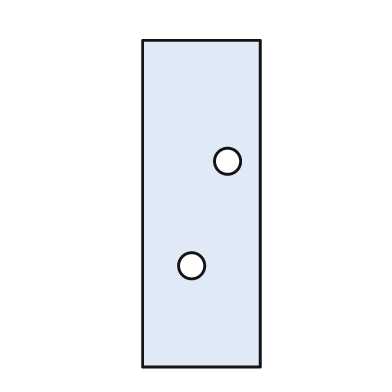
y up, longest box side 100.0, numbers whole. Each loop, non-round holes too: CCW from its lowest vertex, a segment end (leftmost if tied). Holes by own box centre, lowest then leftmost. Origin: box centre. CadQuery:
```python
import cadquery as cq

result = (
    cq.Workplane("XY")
    .moveTo(-18.0, -50.0)
    .lineTo(18.0, -50.0)
    .lineTo(18.0, 50.0)
    .lineTo(-18.0, 50.0)
    .close()
    .moveTo(-3.0, -19.0)
    .circle(4.0)
    .moveTo(8.0, 13.0)
    .circle(4.0)
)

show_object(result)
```